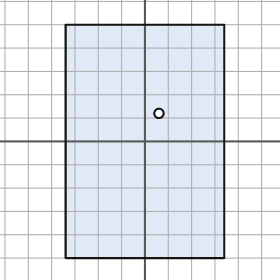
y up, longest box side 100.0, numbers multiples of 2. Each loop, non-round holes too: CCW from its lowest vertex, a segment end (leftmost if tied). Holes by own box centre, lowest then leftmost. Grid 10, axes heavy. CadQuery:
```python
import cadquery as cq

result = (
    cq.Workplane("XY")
    .moveTo(-34.0, -50.0)
    .lineTo(34.0, -50.0)
    .lineTo(34.0, 50.0)
    .lineTo(-34.0, 50.0)
    .close()
    .moveTo(6.0, 12.0)
    .circle(2.0)
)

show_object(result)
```